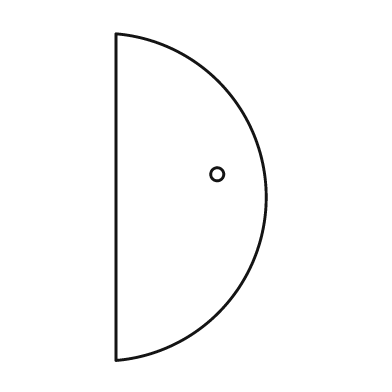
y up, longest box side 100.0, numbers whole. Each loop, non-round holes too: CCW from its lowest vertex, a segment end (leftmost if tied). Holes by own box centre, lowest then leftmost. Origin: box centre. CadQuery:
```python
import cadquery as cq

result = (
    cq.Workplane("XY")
    .moveTo(-23.0, -50.0)
    .threePointArc((23.0, 0.0), (-23.0, 50.0))
    .close()
    .moveTo(8.0, 7.0)
    .circle(2.0)
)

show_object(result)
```